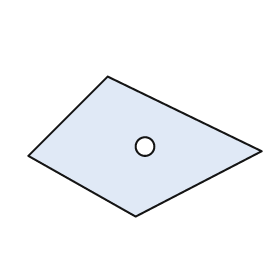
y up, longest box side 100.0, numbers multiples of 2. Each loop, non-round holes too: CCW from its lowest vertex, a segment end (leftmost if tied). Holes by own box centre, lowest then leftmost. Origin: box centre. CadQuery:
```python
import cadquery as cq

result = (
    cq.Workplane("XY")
    .moveTo(-4.0, -30.0)
    .lineTo(50.0, -2.0)
    .lineTo(-16.0, 30.0)
    .lineTo(-50.0, -4.0)
    .close()
    .moveTo(0.0, 0.0)
    .circle(4.0)
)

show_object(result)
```